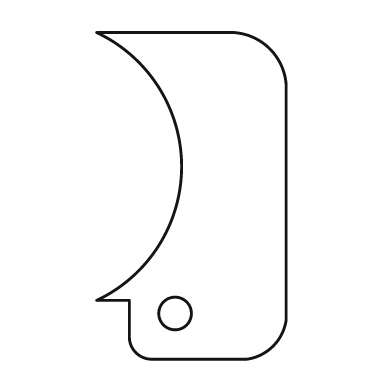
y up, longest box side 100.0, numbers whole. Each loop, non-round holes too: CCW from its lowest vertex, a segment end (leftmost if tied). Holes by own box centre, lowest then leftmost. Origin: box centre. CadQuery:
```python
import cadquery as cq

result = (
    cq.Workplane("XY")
    .moveTo(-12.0, -50.0)
    .lineTo(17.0, -50.0)
    .threePointArc((25.0, -46.0), (29.0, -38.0))
    .lineTo(29.0, 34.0)
    .threePointArc((24.0, 45.0), (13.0, 50.0))
    .lineTo(-29.0, 50.0)
    .threePointArc((-3.0, 9.0), (-29.0, -32.0))
    .lineTo(-19.0, -32.0)
    .lineTo(-19.0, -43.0)
    .threePointArc((-17.0, -48.0), (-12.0, -50.0))
    .close()
    .moveTo(-5.0, -36.0)
    .circle(5.0)
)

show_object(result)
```